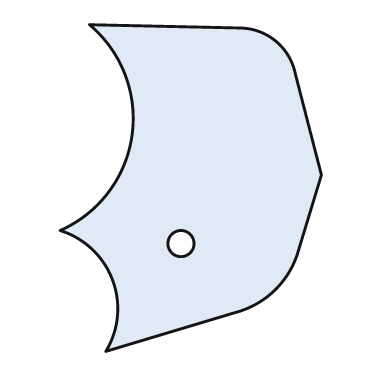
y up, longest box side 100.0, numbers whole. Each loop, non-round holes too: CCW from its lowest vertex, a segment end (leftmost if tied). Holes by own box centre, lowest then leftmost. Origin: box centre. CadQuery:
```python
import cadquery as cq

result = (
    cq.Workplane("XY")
    .moveTo(-26.0, -50.0)
    .lineTo(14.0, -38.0)
    .threePointArc((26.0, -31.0), (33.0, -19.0))
    .lineTo(40.0, 4.0)
    .lineTo(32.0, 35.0)
    .threePointArc((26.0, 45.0), (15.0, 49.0))
    .lineTo(-31.0, 50.0)
    .threePointArc((-18.0, 16.0), (-40.0, -13.0))
    .threePointArc((-24.0, -28.0), (-26.0, -50.0))
    .close()
    .moveTo(-3.0, -17.0)
    .circle(4.0)
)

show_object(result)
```